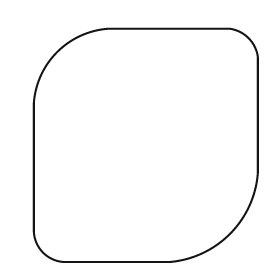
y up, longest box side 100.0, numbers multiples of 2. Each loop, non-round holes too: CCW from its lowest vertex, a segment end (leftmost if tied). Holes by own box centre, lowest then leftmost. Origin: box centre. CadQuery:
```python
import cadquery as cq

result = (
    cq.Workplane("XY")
    .moveTo(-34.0, -50.0)
    .lineTo(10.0, -50.0)
    .threePointArc((36.0, -38.0), (48.0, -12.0))
    .lineTo(48.0, 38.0)
    .threePointArc((44.0, 46.0), (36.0, 50.0))
    .lineTo(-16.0, 50.0)
    .threePointArc((-38.0, 40.0), (-48.0, 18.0))
    .lineTo(-48.0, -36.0)
    .threePointArc((-44.0, -46.0), (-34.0, -50.0))
    .close()
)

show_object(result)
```